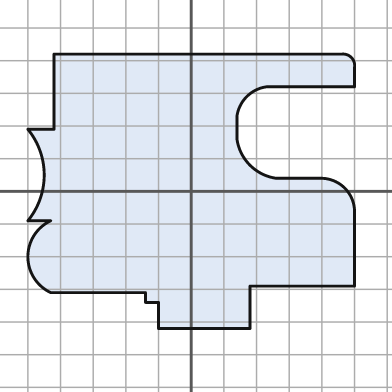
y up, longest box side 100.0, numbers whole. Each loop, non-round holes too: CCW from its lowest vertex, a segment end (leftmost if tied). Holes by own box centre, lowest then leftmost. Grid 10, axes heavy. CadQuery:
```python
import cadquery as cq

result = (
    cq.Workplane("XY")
    .moveTo(-10.0, -42.0)
    .lineTo(18.0, -42.0)
    .lineTo(18.0, -29.0)
    .lineTo(50.0, -29.0)
    .lineTo(50.0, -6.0)
    .threePointArc((47.0, 1.0), (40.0, 4.0))
    .lineTo(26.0, 4.0)
    .threePointArc((18.0, 8.0), (14.0, 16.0))
    .lineTo(14.0, 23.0)
    .threePointArc((17.0, 29.0), (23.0, 32.0))
    .lineTo(50.0, 32.0)
    .lineTo(50.0, 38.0)
    .threePointArc((49.0, 41.0), (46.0, 42.0))
    .lineTo(-42.0, 42.0)
    .lineTo(-42.0, 19.0)
    .lineTo(-50.0, 19.0)
    .threePointArc((-45.0, 5.0), (-50.0, -9.0))
    .lineTo(-43.0, -9.0)
    .threePointArc((-50.0, -20.0), (-43.0, -31.0))
    .lineTo(-14.0, -31.0)
    .lineTo(-14.0, -34.0)
    .lineTo(-10.0, -34.0)
    .close()
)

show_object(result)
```